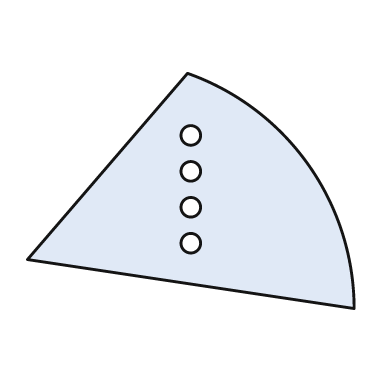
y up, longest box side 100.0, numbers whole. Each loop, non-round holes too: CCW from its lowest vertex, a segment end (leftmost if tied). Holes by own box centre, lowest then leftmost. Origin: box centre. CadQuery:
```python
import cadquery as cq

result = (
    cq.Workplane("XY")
    .moveTo(50.0, -36.0)
    .threePointArc((36.0, 8.0), (-1.0, 36.0))
    .lineTo(-50.0, -21.0)
    .close()
    .moveTo(0.0, -16.0)
    .circle(3.0)
    .moveTo(0.0, -5.0)
    .circle(3.0)
    .moveTo(0.0, 6.0)
    .circle(3.0)
    .moveTo(0.0, 17.0)
    .circle(3.0)
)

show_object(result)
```